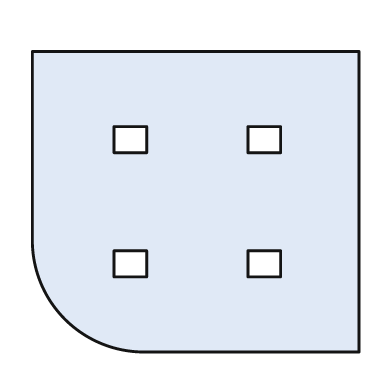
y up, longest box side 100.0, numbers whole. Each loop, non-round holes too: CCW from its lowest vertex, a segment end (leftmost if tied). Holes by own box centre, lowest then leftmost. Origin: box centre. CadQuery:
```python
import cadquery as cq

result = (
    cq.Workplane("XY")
    .moveTo(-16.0, -46.0)
    .lineTo(50.0, -46.0)
    .lineTo(50.0, 46.0)
    .lineTo(-50.0, 46.0)
    .lineTo(-50.0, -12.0)
    .threePointArc((-40.0, -36.0), (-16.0, -46.0))
    .close()
    .moveTo(-25.0, -23.0)
    .lineTo(-15.0, -23.0)
    .lineTo(-15.0, -15.0)
    .lineTo(-25.0, -15.0)
    .close()
    .moveTo(16.0, -23.0)
    .lineTo(26.0, -23.0)
    .lineTo(26.0, -15.0)
    .lineTo(16.0, -15.0)
    .close()
    .moveTo(-25.0, 15.0)
    .lineTo(-15.0, 15.0)
    .lineTo(-15.0, 23.0)
    .lineTo(-25.0, 23.0)
    .close()
    .moveTo(16.0, 15.0)
    .lineTo(26.0, 15.0)
    .lineTo(26.0, 23.0)
    .lineTo(16.0, 23.0)
    .close()
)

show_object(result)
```